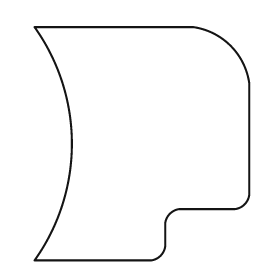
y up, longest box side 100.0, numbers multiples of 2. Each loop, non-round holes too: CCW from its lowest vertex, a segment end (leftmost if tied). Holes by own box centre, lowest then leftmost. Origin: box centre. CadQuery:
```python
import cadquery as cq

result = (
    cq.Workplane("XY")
    .moveTo(-46.0, -50.0)
    .lineTo(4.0, -50.0)
    .threePointArc((8.0, -48.0), (10.0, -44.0))
    .lineTo(10.0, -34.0)
    .threePointArc((12.0, -30.0), (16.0, -28.0))
    .lineTo(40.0, -28.0)
    .threePointArc((44.0, -26.0), (46.0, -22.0))
    .lineTo(46.0, 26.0)
    .threePointArc((38.0, 42.0), (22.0, 50.0))
    .lineTo(-46.0, 50.0)
    .threePointArc((-30.0, 0.0), (-46.0, -50.0))
    .close()
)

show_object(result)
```